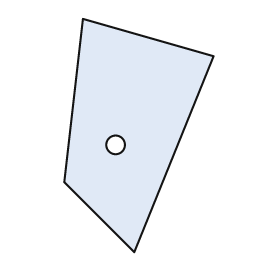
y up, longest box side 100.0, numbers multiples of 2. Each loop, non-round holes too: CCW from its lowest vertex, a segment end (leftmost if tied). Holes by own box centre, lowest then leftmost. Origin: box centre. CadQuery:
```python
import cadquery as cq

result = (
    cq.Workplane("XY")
    .moveTo(-2.0, -50.0)
    .lineTo(32.0, 34.0)
    .lineTo(-24.0, 50.0)
    .lineTo(-32.0, -20.0)
    .close()
    .moveTo(-10.0, -4.0)
    .circle(4.0)
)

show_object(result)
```